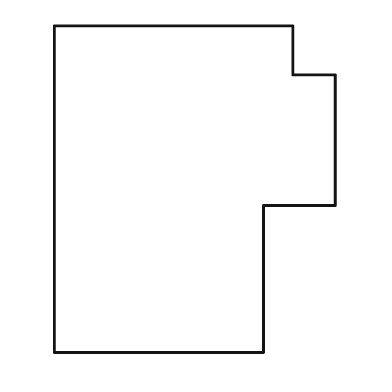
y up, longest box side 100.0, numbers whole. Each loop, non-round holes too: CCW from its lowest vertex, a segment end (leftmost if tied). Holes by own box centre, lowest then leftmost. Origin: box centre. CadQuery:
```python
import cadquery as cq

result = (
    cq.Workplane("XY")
    .moveTo(-43.0, -50.0)
    .lineTo(21.0, -50.0)
    .lineTo(21.0, -5.0)
    .lineTo(43.0, -5.0)
    .lineTo(43.0, 35.0)
    .lineTo(30.0, 35.0)
    .lineTo(30.0, 50.0)
    .lineTo(-43.0, 50.0)
    .close()
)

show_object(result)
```